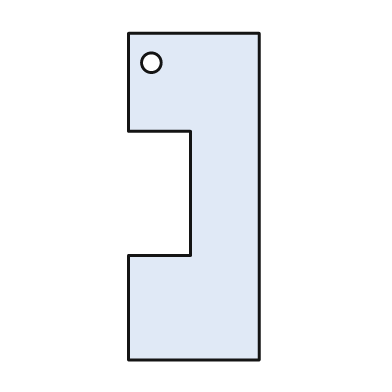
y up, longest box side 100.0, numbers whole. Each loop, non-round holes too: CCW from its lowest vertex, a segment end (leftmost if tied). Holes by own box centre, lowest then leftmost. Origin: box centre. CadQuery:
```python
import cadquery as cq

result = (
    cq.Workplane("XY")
    .moveTo(-20.0, -50.0)
    .lineTo(20.0, -50.0)
    .lineTo(20.0, 50.0)
    .lineTo(-20.0, 50.0)
    .lineTo(-20.0, 20.0)
    .lineTo(-1.0, 20.0)
    .lineTo(-1.0, -18.0)
    .lineTo(-20.0, -18.0)
    .close()
    .moveTo(-13.0, 41.0)
    .circle(3.0)
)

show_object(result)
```